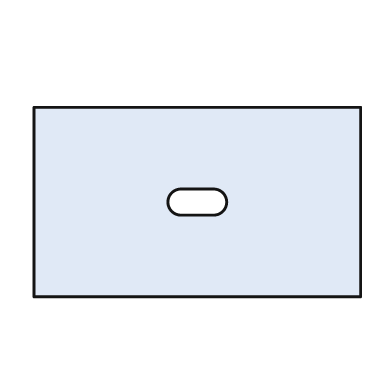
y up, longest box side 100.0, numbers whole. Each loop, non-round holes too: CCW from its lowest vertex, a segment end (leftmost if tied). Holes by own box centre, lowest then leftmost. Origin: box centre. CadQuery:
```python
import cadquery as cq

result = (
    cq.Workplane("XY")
    .moveTo(-50.0, -29.0)
    .lineTo(50.0, -29.0)
    .lineTo(50.0, 29.0)
    .lineTo(-50.0, 29.0)
    .close()
    .moveTo(-5.0, -4.0)
    .lineTo(5.0, -4.0)
    .threePointArc((9.0, 0.0), (5.0, 4.0))
    .lineTo(-5.0, 4.0)
    .threePointArc((-9.0, 0.0), (-5.0, -4.0))
    .close()
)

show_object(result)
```